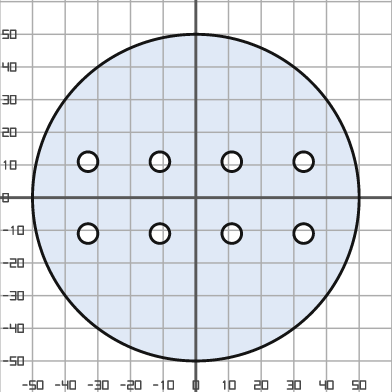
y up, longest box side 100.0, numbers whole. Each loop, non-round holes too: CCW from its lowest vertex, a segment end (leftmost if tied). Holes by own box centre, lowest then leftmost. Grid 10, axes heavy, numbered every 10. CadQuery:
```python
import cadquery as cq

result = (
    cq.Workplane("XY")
    .moveTo(0.0, 0.0)
    .circle(50.0)
    .moveTo(-33.0, -11.0)
    .circle(3.0)
    .moveTo(-11.0, -11.0)
    .circle(3.0)
    .moveTo(11.0, -11.0)
    .circle(3.0)
    .moveTo(33.0, -11.0)
    .circle(3.0)
    .moveTo(-33.0, 11.0)
    .circle(3.0)
    .moveTo(-11.0, 11.0)
    .circle(3.0)
    .moveTo(11.0, 11.0)
    .circle(3.0)
    .moveTo(33.0, 11.0)
    .circle(3.0)
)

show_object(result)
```